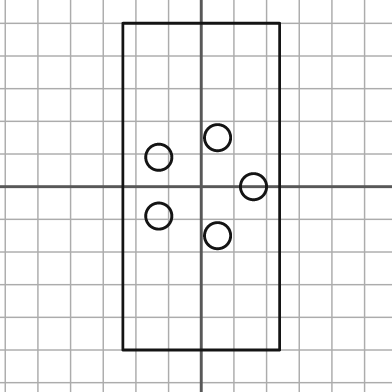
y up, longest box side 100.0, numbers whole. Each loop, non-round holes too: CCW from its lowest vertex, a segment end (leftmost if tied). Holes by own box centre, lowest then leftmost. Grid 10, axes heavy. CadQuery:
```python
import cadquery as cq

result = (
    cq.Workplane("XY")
    .moveTo(-24.0, -50.0)
    .lineTo(24.0, -50.0)
    .lineTo(24.0, 50.0)
    .lineTo(-24.0, 50.0)
    .close()
    .moveTo(5.0, -15.0)
    .circle(4.0)
    .moveTo(-13.0, -9.0)
    .circle(4.0)
    .moveTo(16.0, 0.0)
    .circle(4.0)
    .moveTo(-13.0, 9.0)
    .circle(4.0)
    .moveTo(5.0, 15.0)
    .circle(4.0)
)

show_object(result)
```